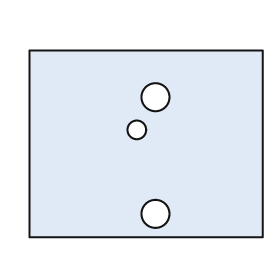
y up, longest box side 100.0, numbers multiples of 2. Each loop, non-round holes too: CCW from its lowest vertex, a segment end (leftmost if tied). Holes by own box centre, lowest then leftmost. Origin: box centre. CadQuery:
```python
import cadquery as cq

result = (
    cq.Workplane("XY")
    .moveTo(-50.0, -40.0)
    .lineTo(50.0, -40.0)
    .lineTo(50.0, 40.0)
    .lineTo(-50.0, 40.0)
    .close()
    .moveTo(4.0, -30.0)
    .circle(6.0)
    .moveTo(-4.0, 6.0)
    .circle(4.0)
    .moveTo(4.0, 20.0)
    .circle(6.0)
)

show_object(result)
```